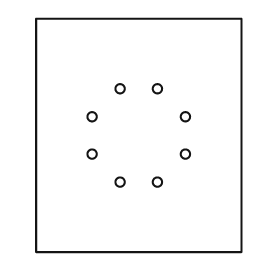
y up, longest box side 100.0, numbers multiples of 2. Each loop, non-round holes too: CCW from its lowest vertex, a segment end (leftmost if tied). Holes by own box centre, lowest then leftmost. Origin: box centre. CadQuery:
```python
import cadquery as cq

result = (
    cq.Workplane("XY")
    .moveTo(-44.0, -50.0)
    .lineTo(44.0, -50.0)
    .lineTo(44.0, 50.0)
    .lineTo(-44.0, 50.0)
    .close()
    .moveTo(-8.0, -20.0)
    .circle(2.0)
    .moveTo(8.0, -20.0)
    .circle(2.0)
    .moveTo(-20.0, -8.0)
    .circle(2.0)
    .moveTo(20.0, -8.0)
    .circle(2.0)
    .moveTo(-20.0, 8.0)
    .circle(2.0)
    .moveTo(20.0, 8.0)
    .circle(2.0)
    .moveTo(-8.0, 20.0)
    .circle(2.0)
    .moveTo(8.0, 20.0)
    .circle(2.0)
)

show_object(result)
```